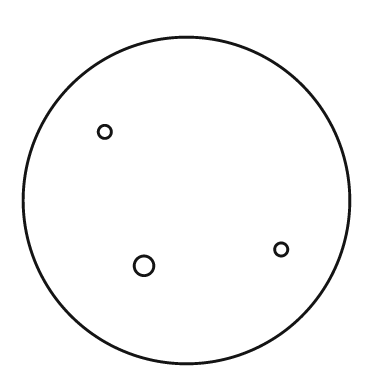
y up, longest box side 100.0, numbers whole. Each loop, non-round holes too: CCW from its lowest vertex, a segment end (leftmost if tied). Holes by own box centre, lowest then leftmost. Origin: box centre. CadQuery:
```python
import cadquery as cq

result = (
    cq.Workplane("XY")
    .moveTo(0.0, 0.0)
    .circle(50.0)
    .moveTo(-13.0, -20.0)
    .circle(3.0)
    .moveTo(29.0, -15.0)
    .circle(2.0)
    .moveTo(-25.0, 21.0)
    .circle(2.0)
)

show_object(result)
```